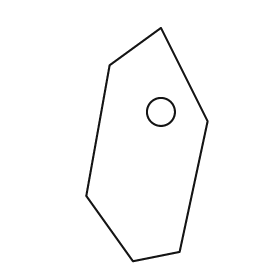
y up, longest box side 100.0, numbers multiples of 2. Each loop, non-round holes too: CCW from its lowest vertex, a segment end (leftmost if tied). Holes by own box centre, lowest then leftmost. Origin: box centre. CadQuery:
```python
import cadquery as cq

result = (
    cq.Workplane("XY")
    .moveTo(-6.0, -50.0)
    .lineTo(14.0, -46.0)
    .lineTo(26.0, 10.0)
    .lineTo(6.0, 50.0)
    .lineTo(-16.0, 34.0)
    .lineTo(-26.0, -22.0)
    .close()
    .moveTo(6.0, 14.0)
    .circle(6.0)
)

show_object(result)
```